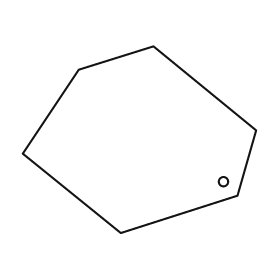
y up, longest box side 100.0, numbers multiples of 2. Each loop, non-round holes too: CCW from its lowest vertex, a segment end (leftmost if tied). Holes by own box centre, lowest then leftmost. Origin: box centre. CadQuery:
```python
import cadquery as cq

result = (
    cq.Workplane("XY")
    .moveTo(-8.0, -40.0)
    .lineTo(42.0, -24.0)
    .lineTo(50.0, 4.0)
    .lineTo(6.0, 40.0)
    .lineTo(-26.0, 30.0)
    .lineTo(-50.0, -6.0)
    .close()
    .moveTo(36.0, -18.0)
    .circle(2.0)
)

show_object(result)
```